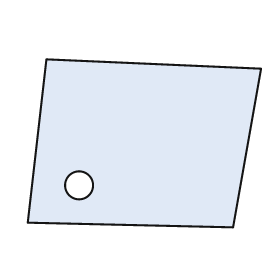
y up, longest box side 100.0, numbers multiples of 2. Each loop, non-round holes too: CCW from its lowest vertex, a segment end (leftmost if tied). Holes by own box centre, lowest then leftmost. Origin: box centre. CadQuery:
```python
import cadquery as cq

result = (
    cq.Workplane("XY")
    .moveTo(38.0, -36.0)
    .lineTo(50.0, 32.0)
    .lineTo(-42.0, 36.0)
    .lineTo(-50.0, -34.0)
    .close()
    .moveTo(-28.0, -18.0)
    .circle(6.0)
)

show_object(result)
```